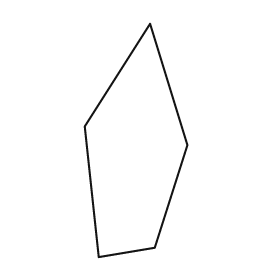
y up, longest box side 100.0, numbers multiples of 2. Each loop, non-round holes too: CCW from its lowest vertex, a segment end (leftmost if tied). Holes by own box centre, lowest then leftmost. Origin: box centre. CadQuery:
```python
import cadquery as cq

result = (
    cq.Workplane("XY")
    .moveTo(-16.0, -50.0)
    .lineTo(8.0, -46.0)
    .lineTo(22.0, -2.0)
    .lineTo(6.0, 50.0)
    .lineTo(-22.0, 6.0)
    .close()
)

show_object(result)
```